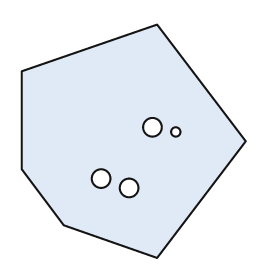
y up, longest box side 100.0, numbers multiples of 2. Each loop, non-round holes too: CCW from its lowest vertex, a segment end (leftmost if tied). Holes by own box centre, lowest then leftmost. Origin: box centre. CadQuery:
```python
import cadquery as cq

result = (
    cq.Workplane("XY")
    .moveTo(10.0, -50.0)
    .lineTo(48.0, 0.0)
    .lineTo(10.0, 50.0)
    .lineTo(-48.0, 30.0)
    .lineTo(-48.0, -12.0)
    .lineTo(-30.0, -36.0)
    .close()
    .moveTo(-2.0, -20.0)
    .circle(4.0)
    .moveTo(-14.0, -16.0)
    .circle(4.0)
    .moveTo(18.0, 4.0)
    .circle(2.0)
    .moveTo(8.0, 6.0)
    .circle(4.0)
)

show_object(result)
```